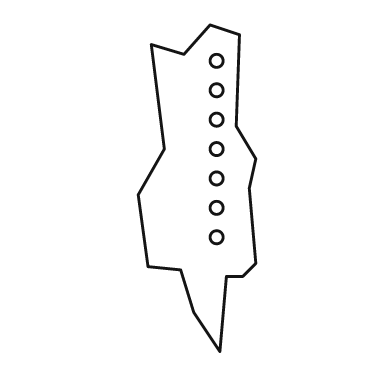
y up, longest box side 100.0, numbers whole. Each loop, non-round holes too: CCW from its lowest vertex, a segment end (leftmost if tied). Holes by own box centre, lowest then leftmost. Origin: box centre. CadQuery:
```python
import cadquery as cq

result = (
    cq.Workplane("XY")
    .moveTo(7.0, -50.0)
    .lineTo(9.0, -27.0)
    .lineTo(14.0, -27.0)
    .lineTo(18.0, -23.0)
    .lineTo(16.0, 0.0)
    .lineTo(18.0, 9.0)
    .lineTo(12.0, 19.0)
    .lineTo(13.0, 47.0)
    .lineTo(4.0, 50.0)
    .lineTo(-4.0, 41.0)
    .lineTo(-14.0, 44.0)
    .lineTo(-10.0, 12.0)
    .lineTo(-18.0, -2.0)
    .lineTo(-15.0, -24.0)
    .lineTo(-5.0, -25.0)
    .lineTo(-1.0, -38.0)
    .close()
    .moveTo(6.0, -15.0)
    .circle(2.0)
    .moveTo(6.0, -6.0)
    .circle(2.0)
    .moveTo(6.0, 3.0)
    .circle(2.0)
    .moveTo(6.0, 12.0)
    .circle(2.0)
    .moveTo(6.0, 21.0)
    .circle(2.0)
    .moveTo(6.0, 30.0)
    .circle(2.0)
    .moveTo(6.0, 39.0)
    .circle(2.0)
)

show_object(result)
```